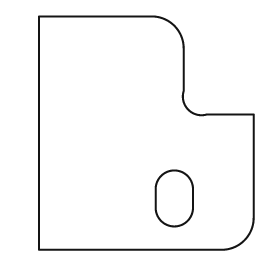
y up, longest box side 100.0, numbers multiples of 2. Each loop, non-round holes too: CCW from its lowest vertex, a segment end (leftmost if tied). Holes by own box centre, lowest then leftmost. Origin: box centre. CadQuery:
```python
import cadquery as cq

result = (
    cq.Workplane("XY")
    .moveTo(-46.0, -50.0)
    .lineTo(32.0, -50.0)
    .threePointArc((42.0, -46.0), (46.0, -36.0))
    .lineTo(46.0, 8.0)
    .lineTo(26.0, 8.0)
    .threePointArc((18.0, 10.0), (16.0, 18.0))
    .lineTo(16.0, 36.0)
    .threePointArc((12.0, 46.0), (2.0, 50.0))
    .lineTo(-46.0, 50.0)
    .close()
    .moveTo(4.0, -32.0)
    .threePointArc((12.0, -40.0), (20.0, -32.0))
    .lineTo(20.0, -24.0)
    .threePointArc((12.0, -16.0), (4.0, -24.0))
    .close()
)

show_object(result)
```